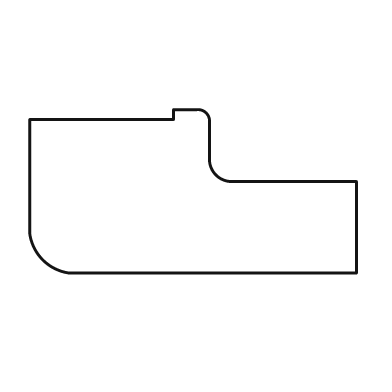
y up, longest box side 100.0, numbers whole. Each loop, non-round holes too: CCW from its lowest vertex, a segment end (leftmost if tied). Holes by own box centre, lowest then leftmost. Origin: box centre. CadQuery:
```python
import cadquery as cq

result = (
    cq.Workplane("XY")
    .moveTo(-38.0, -25.0)
    .lineTo(50.0, -25.0)
    .lineTo(50.0, 3.0)
    .lineTo(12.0, 3.0)
    .threePointArc((7.0, 5.0), (5.0, 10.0))
    .lineTo(5.0, 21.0)
    .threePointArc((4.0, 24.0), (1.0, 25.0))
    .lineTo(-6.0, 25.0)
    .lineTo(-6.0, 22.0)
    .lineTo(-50.0, 22.0)
    .lineTo(-50.0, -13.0)
    .threePointArc((-46.0, -21.0), (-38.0, -25.0))
    .close()
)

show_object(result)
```